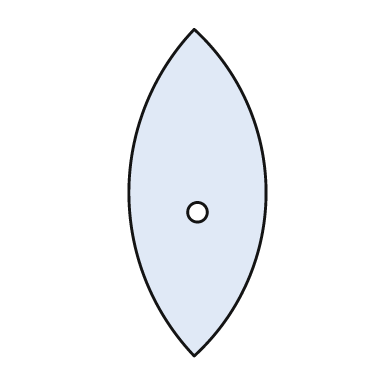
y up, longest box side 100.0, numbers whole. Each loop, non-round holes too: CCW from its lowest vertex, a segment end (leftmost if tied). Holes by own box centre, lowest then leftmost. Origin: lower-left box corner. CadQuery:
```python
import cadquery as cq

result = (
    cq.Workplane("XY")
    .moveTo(20.0, 0.0)
    .threePointArc((42.0, 50.0), (20.0, 100.0))
    .threePointArc((0.0, 50.0), (20.0, 0.0))
    .close()
    .moveTo(21.0, 44.0)
    .circle(3.0)
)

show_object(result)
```